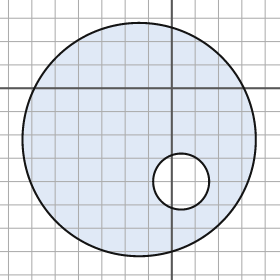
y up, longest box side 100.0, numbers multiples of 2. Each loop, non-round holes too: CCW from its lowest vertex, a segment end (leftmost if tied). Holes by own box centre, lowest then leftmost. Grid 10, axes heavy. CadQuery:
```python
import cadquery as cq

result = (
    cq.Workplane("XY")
    .moveTo(-14.0, -22.0)
    .circle(50.0)
    .moveTo(4.0, -40.0)
    .circle(12.0)
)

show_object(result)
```